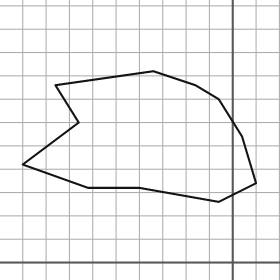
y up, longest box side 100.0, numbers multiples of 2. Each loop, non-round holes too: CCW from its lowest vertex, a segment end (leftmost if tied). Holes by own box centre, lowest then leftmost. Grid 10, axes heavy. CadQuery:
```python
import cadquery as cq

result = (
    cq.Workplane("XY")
    .moveTo(-6.0, 26.0)
    .lineTo(10.0, 34.0)
    .lineTo(4.0, 54.0)
    .lineTo(-6.0, 70.0)
    .lineTo(-16.0, 76.0)
    .lineTo(-34.0, 82.0)
    .lineTo(-76.0, 76.0)
    .lineTo(-66.0, 60.0)
    .lineTo(-90.0, 42.0)
    .lineTo(-62.0, 32.0)
    .lineTo(-40.0, 32.0)
    .close()
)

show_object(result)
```